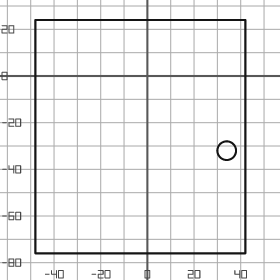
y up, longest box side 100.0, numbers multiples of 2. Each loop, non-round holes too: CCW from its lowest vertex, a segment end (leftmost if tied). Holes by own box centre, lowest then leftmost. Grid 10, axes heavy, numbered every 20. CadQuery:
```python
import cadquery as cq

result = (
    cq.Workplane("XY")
    .moveTo(-48.0, -76.0)
    .lineTo(42.0, -76.0)
    .lineTo(42.0, 24.0)
    .lineTo(-48.0, 24.0)
    .close()
    .moveTo(34.0, -32.0)
    .circle(4.0)
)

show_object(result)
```